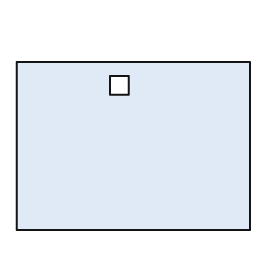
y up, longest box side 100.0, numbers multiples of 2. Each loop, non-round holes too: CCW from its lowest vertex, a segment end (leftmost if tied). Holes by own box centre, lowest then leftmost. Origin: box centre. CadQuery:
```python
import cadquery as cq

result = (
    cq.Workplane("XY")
    .moveTo(-50.0, -36.0)
    .lineTo(50.0, -36.0)
    .lineTo(50.0, 36.0)
    .lineTo(-50.0, 36.0)
    .close()
    .moveTo(-10.0, 22.0)
    .lineTo(-2.0, 22.0)
    .lineTo(-2.0, 30.0)
    .lineTo(-10.0, 30.0)
    .close()
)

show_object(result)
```